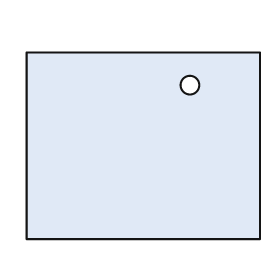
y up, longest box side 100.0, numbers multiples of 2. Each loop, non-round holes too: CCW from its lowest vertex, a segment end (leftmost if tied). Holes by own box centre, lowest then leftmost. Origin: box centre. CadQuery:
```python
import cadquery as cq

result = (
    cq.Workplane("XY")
    .moveTo(-50.0, -40.0)
    .lineTo(50.0, -40.0)
    .lineTo(50.0, 40.0)
    .lineTo(-50.0, 40.0)
    .close()
    .moveTo(20.0, 26.0)
    .circle(4.0)
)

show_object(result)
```